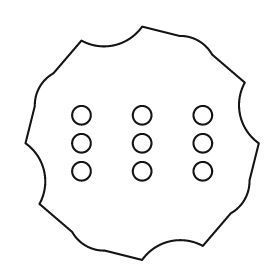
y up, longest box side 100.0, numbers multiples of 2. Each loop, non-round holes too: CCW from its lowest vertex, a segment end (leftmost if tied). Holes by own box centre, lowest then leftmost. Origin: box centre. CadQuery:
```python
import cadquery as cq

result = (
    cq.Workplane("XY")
    .moveTo(0.0, -50.0)
    .threePointArc((12.0, -42.0), (26.0, -44.0))
    .lineTo(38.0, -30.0)
    .threePointArc((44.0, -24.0), (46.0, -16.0))
    .lineTo(50.0, 0.0)
    .threePointArc((42.0, 12.0), (44.0, 26.0))
    .lineTo(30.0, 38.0)
    .threePointArc((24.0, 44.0), (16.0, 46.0))
    .lineTo(0.0, 50.0)
    .threePointArc((-12.0, 42.0), (-26.0, 44.0))
    .lineTo(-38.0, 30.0)
    .threePointArc((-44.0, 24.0), (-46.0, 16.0))
    .lineTo(-50.0, 0.0)
    .threePointArc((-42.0, -12.0), (-44.0, -26.0))
    .lineTo(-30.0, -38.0)
    .threePointArc((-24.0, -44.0), (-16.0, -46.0))
    .close()
    .moveTo(-26.0, -12.0)
    .circle(4.0)
    .moveTo(0.0, -12.0)
    .circle(4.0)
    .moveTo(26.0, -12.0)
    .circle(4.0)
    .moveTo(-26.0, 0.0)
    .circle(4.0)
    .moveTo(0.0, 0.0)
    .circle(4.0)
    .moveTo(26.0, 0.0)
    .circle(4.0)
    .moveTo(-26.0, 12.0)
    .circle(4.0)
    .moveTo(0.0, 12.0)
    .circle(4.0)
    .moveTo(26.0, 12.0)
    .circle(4.0)
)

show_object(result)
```